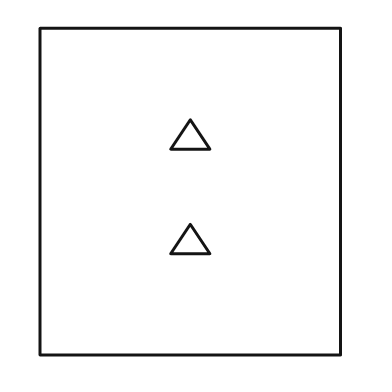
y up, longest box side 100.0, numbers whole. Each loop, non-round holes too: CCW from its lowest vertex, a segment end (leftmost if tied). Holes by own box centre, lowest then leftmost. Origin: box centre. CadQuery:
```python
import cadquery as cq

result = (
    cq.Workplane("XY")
    .moveTo(-46.0, -50.0)
    .lineTo(46.0, -50.0)
    .lineTo(46.0, 50.0)
    .lineTo(-46.0, 50.0)
    .close()
    .moveTo(-6.0, -19.0)
    .lineTo(6.0, -19.0)
    .lineTo(0.0, -10.0)
    .close()
    .moveTo(-6.0, 13.0)
    .lineTo(6.0, 13.0)
    .lineTo(0.0, 22.0)
    .close()
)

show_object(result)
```